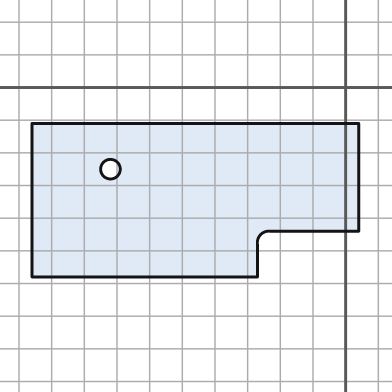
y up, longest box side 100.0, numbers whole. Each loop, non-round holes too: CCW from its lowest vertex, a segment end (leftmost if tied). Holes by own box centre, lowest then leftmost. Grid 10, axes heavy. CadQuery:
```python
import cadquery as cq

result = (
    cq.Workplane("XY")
    .moveTo(-96.0, -58.0)
    .lineTo(-27.0, -58.0)
    .lineTo(-27.0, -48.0)
    .threePointArc((-26.0, -45.0), (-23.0, -44.0))
    .lineTo(4.0, -44.0)
    .lineTo(4.0, -11.0)
    .lineTo(-96.0, -11.0)
    .close()
    .moveTo(-72.0, -25.0)
    .circle(3.0)
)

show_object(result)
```